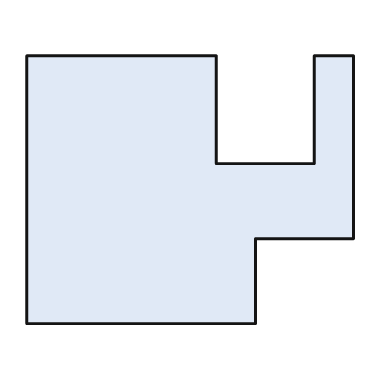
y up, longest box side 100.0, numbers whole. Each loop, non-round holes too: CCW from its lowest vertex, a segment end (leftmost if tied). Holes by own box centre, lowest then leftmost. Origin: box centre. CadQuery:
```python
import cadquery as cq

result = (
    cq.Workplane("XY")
    .moveTo(-50.0, -41.0)
    .lineTo(20.0, -41.0)
    .lineTo(20.0, -15.0)
    .lineTo(50.0, -15.0)
    .lineTo(50.0, 41.0)
    .lineTo(38.0, 41.0)
    .lineTo(38.0, 8.0)
    .lineTo(8.0, 8.0)
    .lineTo(8.0, 41.0)
    .lineTo(-50.0, 41.0)
    .close()
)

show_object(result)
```